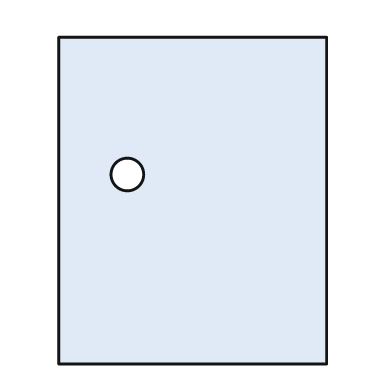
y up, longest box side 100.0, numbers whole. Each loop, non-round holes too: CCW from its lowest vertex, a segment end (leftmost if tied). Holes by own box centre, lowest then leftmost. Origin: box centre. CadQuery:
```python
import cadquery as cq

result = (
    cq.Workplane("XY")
    .moveTo(-41.0, -50.0)
    .lineTo(41.0, -50.0)
    .lineTo(41.0, 50.0)
    .lineTo(-41.0, 50.0)
    .close()
    .moveTo(-20.0, 8.0)
    .circle(5.0)
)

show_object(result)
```